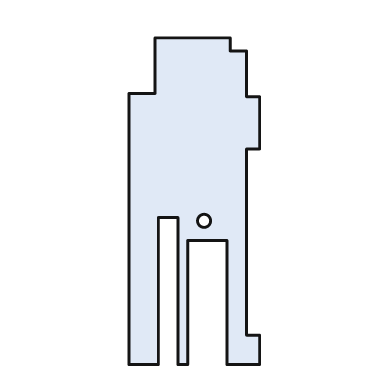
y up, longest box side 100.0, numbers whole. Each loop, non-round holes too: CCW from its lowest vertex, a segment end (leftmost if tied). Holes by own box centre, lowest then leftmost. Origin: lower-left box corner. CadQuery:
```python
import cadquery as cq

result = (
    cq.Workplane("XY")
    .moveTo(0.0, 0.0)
    .lineTo(9.0, 0.0)
    .lineTo(9.0, 45.0)
    .lineTo(15.0, 45.0)
    .lineTo(15.0, 0.0)
    .lineTo(18.0, 0.0)
    .lineTo(18.0, 38.0)
    .lineTo(30.0, 38.0)
    .lineTo(30.0, 0.0)
    .lineTo(40.0, 0.0)
    .lineTo(40.0, 9.0)
    .lineTo(36.0, 9.0)
    .lineTo(36.0, 66.0)
    .lineTo(40.0, 66.0)
    .lineTo(40.0, 82.0)
    .lineTo(36.0, 82.0)
    .lineTo(36.0, 96.0)
    .lineTo(31.0, 96.0)
    .lineTo(31.0, 100.0)
    .lineTo(8.0, 100.0)
    .lineTo(8.0, 83.0)
    .lineTo(0.0, 83.0)
    .close()
    .moveTo(23.0, 44.0)
    .circle(2.0)
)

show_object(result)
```